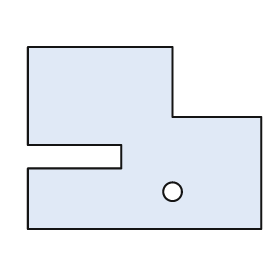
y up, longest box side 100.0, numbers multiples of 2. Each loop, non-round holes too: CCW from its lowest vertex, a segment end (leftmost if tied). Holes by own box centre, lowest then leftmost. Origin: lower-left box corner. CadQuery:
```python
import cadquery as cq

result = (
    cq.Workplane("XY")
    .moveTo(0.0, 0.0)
    .lineTo(100.0, 0.0)
    .lineTo(100.0, 48.0)
    .lineTo(62.0, 48.0)
    .lineTo(62.0, 78.0)
    .lineTo(0.0, 78.0)
    .lineTo(0.0, 36.0)
    .lineTo(40.0, 36.0)
    .lineTo(40.0, 26.0)
    .lineTo(0.0, 26.0)
    .close()
    .moveTo(62.0, 16.0)
    .circle(4.0)
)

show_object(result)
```